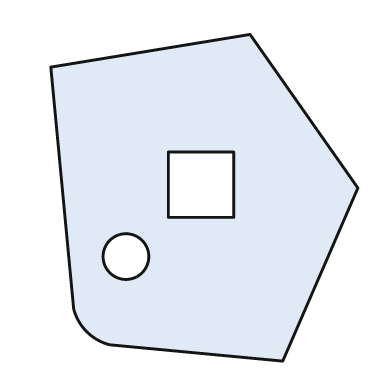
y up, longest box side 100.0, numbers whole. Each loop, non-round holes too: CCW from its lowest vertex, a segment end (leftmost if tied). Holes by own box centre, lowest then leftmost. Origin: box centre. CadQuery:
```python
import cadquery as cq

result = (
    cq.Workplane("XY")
    .moveTo(24.0, -50.0)
    .lineTo(47.0, 3.0)
    .lineTo(14.0, 50.0)
    .lineTo(-47.0, 40.0)
    .lineTo(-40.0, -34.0)
    .threePointArc((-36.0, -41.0), (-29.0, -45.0))
    .close()
    .moveTo(-24.0, -18.0)
    .circle(7.0)
    .moveTo(-11.0, -6.0)
    .lineTo(9.0, -6.0)
    .lineTo(9.0, 14.0)
    .lineTo(-11.0, 14.0)
    .close()
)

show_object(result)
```